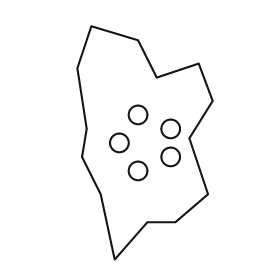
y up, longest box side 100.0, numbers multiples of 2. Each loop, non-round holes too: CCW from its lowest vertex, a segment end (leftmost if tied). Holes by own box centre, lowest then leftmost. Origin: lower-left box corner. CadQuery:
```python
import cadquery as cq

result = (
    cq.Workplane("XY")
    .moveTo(16.0, 0.0)
    .lineTo(30.0, 16.0)
    .lineTo(42.0, 16.0)
    .lineTo(56.0, 28.0)
    .lineTo(48.0, 52.0)
    .lineTo(58.0, 68.0)
    .lineTo(52.0, 84.0)
    .lineTo(34.0, 78.0)
    .lineTo(26.0, 94.0)
    .lineTo(6.0, 100.0)
    .lineTo(0.0, 82.0)
    .lineTo(4.0, 56.0)
    .lineTo(2.0, 44.0)
    .lineTo(10.0, 28.0)
    .close()
    .moveTo(26.0, 38.0)
    .circle(4.0)
    .moveTo(40.0, 44.0)
    .circle(4.0)
    .moveTo(18.0, 50.0)
    .circle(4.0)
    .moveTo(40.0, 56.0)
    .circle(4.0)
    .moveTo(26.0, 62.0)
    .circle(4.0)
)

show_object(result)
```